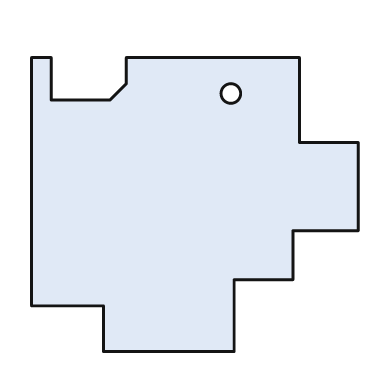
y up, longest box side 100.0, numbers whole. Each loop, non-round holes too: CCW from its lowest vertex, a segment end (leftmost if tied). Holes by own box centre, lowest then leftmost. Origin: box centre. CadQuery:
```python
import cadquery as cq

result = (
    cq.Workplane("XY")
    .moveTo(-28.0, -45.0)
    .lineTo(12.0, -45.0)
    .lineTo(12.0, -23.0)
    .lineTo(30.0, -23.0)
    .lineTo(30.0, -8.0)
    .lineTo(50.0, -8.0)
    .lineTo(50.0, 19.0)
    .lineTo(32.0, 19.0)
    .lineTo(32.0, 45.0)
    .lineTo(-21.0, 45.0)
    .lineTo(-21.0, 37.0)
    .lineTo(-26.0, 32.0)
    .lineTo(-44.0, 32.0)
    .lineTo(-44.0, 45.0)
    .lineTo(-50.0, 45.0)
    .lineTo(-50.0, -31.0)
    .lineTo(-28.0, -31.0)
    .close()
    .moveTo(11.0, 34.0)
    .circle(3.0)
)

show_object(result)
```